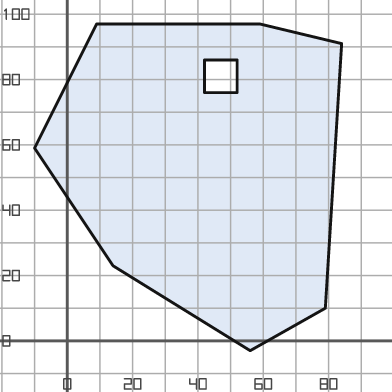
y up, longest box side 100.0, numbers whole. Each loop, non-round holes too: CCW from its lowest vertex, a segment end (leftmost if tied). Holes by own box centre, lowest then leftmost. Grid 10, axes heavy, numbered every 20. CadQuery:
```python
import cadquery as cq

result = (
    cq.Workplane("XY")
    .moveTo(56.0, -3.0)
    .lineTo(79.0, 10.0)
    .lineTo(84.0, 91.0)
    .lineTo(59.0, 97.0)
    .lineTo(9.0, 97.0)
    .lineTo(-10.0, 59.0)
    .lineTo(14.0, 23.0)
    .close()
    .moveTo(42.0, 76.0)
    .lineTo(52.0, 76.0)
    .lineTo(52.0, 86.0)
    .lineTo(42.0, 86.0)
    .close()
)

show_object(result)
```